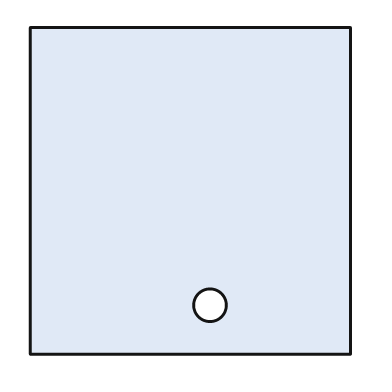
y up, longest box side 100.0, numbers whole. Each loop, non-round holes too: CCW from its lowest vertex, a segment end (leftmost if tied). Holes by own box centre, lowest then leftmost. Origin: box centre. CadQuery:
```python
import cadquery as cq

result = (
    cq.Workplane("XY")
    .moveTo(-49.0, -50.0)
    .lineTo(49.0, -50.0)
    .lineTo(49.0, 50.0)
    .lineTo(-49.0, 50.0)
    .close()
    .moveTo(6.0, -35.0)
    .circle(5.0)
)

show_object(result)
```